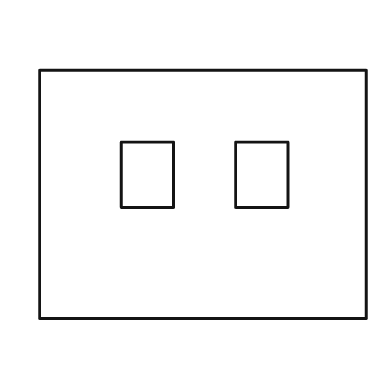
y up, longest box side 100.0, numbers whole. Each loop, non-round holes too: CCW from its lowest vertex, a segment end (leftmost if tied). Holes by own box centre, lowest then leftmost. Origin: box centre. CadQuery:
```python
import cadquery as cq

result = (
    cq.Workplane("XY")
    .moveTo(-50.0, -38.0)
    .lineTo(50.0, -38.0)
    .lineTo(50.0, 38.0)
    .lineTo(-50.0, 38.0)
    .close()
    .moveTo(-25.0, -4.0)
    .lineTo(-9.0, -4.0)
    .lineTo(-9.0, 16.0)
    .lineTo(-25.0, 16.0)
    .close()
    .moveTo(10.0, -4.0)
    .lineTo(26.0, -4.0)
    .lineTo(26.0, 16.0)
    .lineTo(10.0, 16.0)
    .close()
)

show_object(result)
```